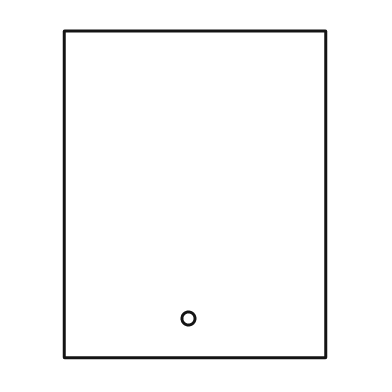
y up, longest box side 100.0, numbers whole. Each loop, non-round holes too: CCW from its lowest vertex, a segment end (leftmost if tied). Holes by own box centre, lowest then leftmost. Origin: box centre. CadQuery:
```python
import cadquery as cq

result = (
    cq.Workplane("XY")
    .moveTo(-40.0, -50.0)
    .lineTo(40.0, -50.0)
    .lineTo(40.0, 50.0)
    .lineTo(-40.0, 50.0)
    .close()
    .moveTo(-2.0, -38.0)
    .circle(2.0)
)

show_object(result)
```